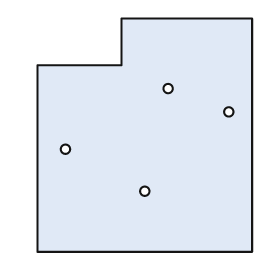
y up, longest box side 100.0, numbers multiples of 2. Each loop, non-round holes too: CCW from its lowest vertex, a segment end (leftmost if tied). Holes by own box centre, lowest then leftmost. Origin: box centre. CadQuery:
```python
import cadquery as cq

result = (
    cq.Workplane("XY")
    .moveTo(-46.0, -50.0)
    .lineTo(46.0, -50.0)
    .lineTo(46.0, 50.0)
    .lineTo(-10.0, 50.0)
    .lineTo(-10.0, 30.0)
    .lineTo(-46.0, 30.0)
    .close()
    .moveTo(0.0, -24.0)
    .circle(2.0)
    .moveTo(-34.0, -6.0)
    .circle(2.0)
    .moveTo(36.0, 10.0)
    .circle(2.0)
    .moveTo(10.0, 20.0)
    .circle(2.0)
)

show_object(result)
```